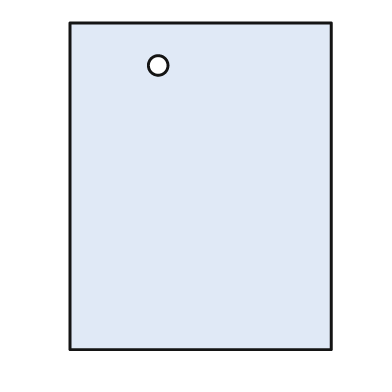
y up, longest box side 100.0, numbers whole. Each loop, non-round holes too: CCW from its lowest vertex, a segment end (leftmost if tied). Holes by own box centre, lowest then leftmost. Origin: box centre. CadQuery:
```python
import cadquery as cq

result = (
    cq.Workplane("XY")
    .moveTo(-40.0, -50.0)
    .lineTo(40.0, -50.0)
    .lineTo(40.0, 50.0)
    .lineTo(-40.0, 50.0)
    .close()
    .moveTo(-13.0, 37.0)
    .circle(3.0)
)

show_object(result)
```